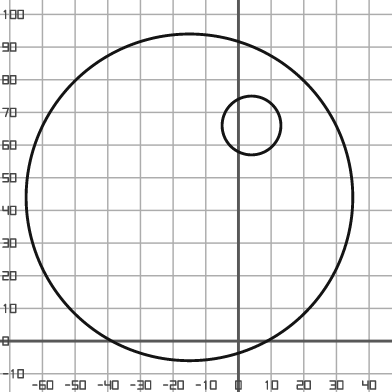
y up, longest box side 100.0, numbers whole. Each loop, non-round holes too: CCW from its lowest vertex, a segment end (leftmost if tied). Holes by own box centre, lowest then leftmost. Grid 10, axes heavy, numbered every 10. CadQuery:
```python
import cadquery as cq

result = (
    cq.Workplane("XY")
    .moveTo(-15.0, 44.0)
    .circle(50.0)
    .moveTo(4.0, 66.0)
    .circle(9.0)
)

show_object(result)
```